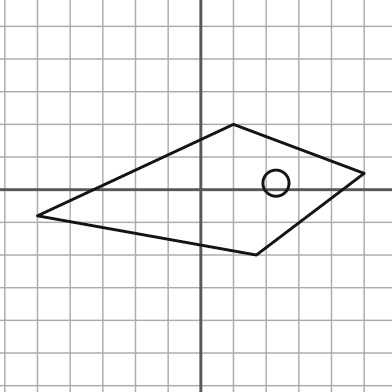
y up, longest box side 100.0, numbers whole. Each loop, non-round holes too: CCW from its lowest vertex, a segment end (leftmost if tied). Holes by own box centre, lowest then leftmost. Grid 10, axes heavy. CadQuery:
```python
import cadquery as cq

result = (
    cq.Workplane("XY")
    .moveTo(17.0, -20.0)
    .lineTo(50.0, 5.0)
    .lineTo(10.0, 20.0)
    .lineTo(-50.0, -8.0)
    .close()
    .moveTo(23.0, 2.0)
    .circle(4.0)
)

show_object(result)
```